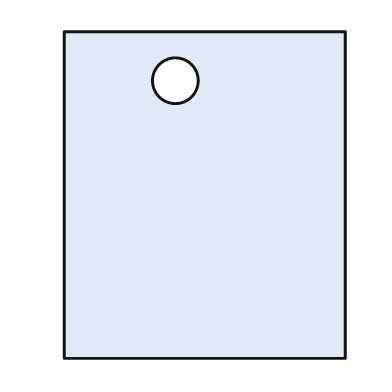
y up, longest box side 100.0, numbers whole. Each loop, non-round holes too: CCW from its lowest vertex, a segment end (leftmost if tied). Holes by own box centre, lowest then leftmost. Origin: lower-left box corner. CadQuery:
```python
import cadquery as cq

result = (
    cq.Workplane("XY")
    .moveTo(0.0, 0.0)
    .lineTo(86.0, 0.0)
    .lineTo(86.0, 100.0)
    .lineTo(0.0, 100.0)
    .close()
    .moveTo(34.0, 85.0)
    .circle(7.0)
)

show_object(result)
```